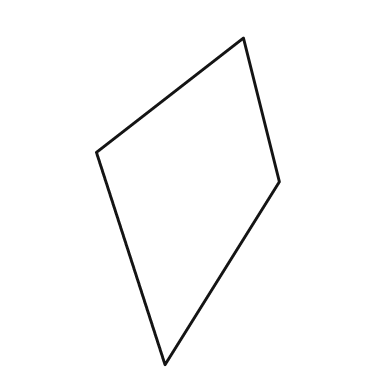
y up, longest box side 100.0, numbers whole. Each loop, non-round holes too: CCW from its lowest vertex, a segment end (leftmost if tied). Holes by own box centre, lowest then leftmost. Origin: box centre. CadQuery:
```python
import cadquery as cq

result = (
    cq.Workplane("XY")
    .moveTo(-7.0, -50.0)
    .lineTo(28.0, 6.0)
    .lineTo(17.0, 50.0)
    .lineTo(-28.0, 15.0)
    .close()
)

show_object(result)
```